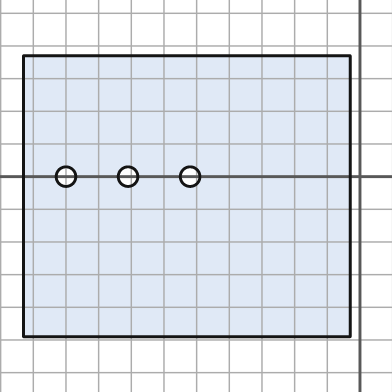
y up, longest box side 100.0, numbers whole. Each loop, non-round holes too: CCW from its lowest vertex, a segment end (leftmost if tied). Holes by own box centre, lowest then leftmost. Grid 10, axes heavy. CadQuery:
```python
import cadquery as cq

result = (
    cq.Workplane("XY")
    .moveTo(-103.0, -49.0)
    .lineTo(-3.0, -49.0)
    .lineTo(-3.0, 37.0)
    .lineTo(-103.0, 37.0)
    .close()
    .moveTo(-90.0, 0.0)
    .circle(3.0)
    .moveTo(-71.0, 0.0)
    .circle(3.0)
    .moveTo(-52.0, 0.0)
    .circle(3.0)
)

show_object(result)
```